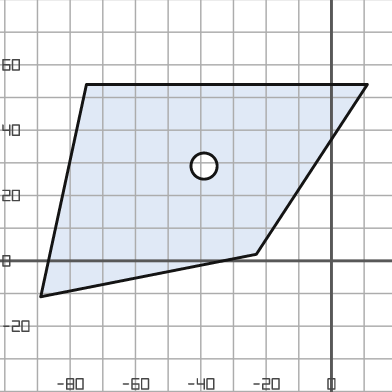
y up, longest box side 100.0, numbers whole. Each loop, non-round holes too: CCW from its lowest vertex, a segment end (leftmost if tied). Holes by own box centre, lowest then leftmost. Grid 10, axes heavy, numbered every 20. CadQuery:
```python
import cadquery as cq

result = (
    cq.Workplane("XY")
    .moveTo(-89.0, -11.0)
    .lineTo(-23.0, 2.0)
    .lineTo(11.0, 54.0)
    .lineTo(-75.0, 54.0)
    .close()
    .moveTo(-39.0, 29.0)
    .circle(4.0)
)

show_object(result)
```